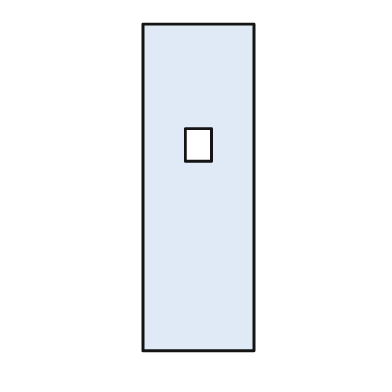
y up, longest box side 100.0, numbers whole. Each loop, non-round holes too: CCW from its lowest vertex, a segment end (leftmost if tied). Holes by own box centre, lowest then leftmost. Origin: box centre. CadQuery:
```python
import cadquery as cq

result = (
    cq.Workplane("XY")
    .moveTo(-17.0, -50.0)
    .lineTo(17.0, -50.0)
    .lineTo(17.0, 50.0)
    .lineTo(-17.0, 50.0)
    .close()
    .moveTo(-4.0, 8.0)
    .lineTo(4.0, 8.0)
    .lineTo(4.0, 18.0)
    .lineTo(-4.0, 18.0)
    .close()
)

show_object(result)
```